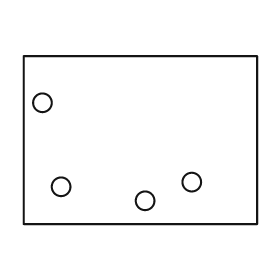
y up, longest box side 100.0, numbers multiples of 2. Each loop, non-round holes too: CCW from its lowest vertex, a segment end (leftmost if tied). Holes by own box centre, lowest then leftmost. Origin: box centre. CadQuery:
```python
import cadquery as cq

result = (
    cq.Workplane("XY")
    .moveTo(-50.0, -36.0)
    .lineTo(50.0, -36.0)
    .lineTo(50.0, 36.0)
    .lineTo(-50.0, 36.0)
    .close()
    .moveTo(2.0, -26.0)
    .circle(4.0)
    .moveTo(-34.0, -20.0)
    .circle(4.0)
    .moveTo(22.0, -18.0)
    .circle(4.0)
    .moveTo(-42.0, 16.0)
    .circle(4.0)
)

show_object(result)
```